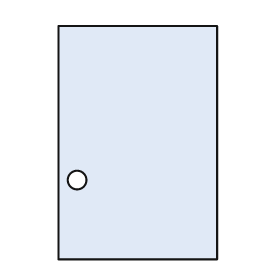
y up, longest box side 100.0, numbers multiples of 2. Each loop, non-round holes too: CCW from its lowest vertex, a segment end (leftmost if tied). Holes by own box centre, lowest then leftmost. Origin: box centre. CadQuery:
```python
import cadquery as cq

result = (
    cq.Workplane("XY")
    .moveTo(-34.0, -50.0)
    .lineTo(34.0, -50.0)
    .lineTo(34.0, 50.0)
    .lineTo(-34.0, 50.0)
    .close()
    .moveTo(-26.0, -16.0)
    .circle(4.0)
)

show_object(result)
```